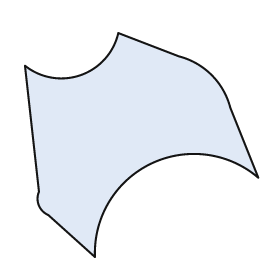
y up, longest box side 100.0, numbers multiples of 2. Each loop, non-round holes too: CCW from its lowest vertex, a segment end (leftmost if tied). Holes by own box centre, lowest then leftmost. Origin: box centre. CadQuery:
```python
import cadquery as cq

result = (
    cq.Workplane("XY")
    .moveTo(-20.0, -48.0)
    .threePointArc((4.0, -8.0), (50.0, -14.0))
    .lineTo(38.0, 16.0)
    .threePointArc((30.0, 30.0), (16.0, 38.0))
    .lineTo(-10.0, 48.0)
    .threePointArc((-26.0, 30.0), (-50.0, 34.0))
    .lineTo(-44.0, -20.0)
    .threePointArc((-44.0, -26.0), (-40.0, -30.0))
    .close()
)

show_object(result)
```